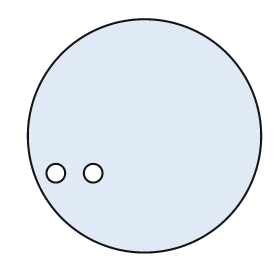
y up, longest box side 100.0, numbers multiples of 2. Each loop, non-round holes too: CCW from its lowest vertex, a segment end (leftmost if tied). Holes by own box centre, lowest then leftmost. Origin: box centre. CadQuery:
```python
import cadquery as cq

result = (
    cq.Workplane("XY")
    .moveTo(0.0, 0.0)
    .circle(50.0)
    .moveTo(-38.0, -16.0)
    .circle(4.0)
    .moveTo(-22.0, -16.0)
    .circle(4.0)
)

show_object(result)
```